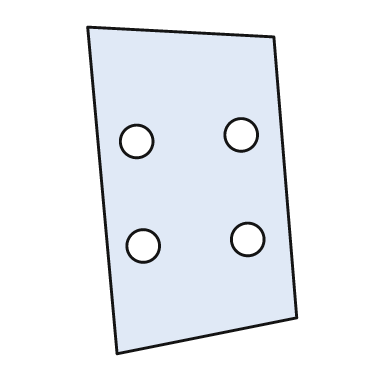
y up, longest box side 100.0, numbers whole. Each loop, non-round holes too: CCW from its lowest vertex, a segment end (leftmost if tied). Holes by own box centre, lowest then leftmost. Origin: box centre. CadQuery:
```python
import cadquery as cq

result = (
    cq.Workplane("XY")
    .moveTo(-23.0, -50.0)
    .lineTo(32.0, -39.0)
    .lineTo(25.0, 47.0)
    .lineTo(-32.0, 50.0)
    .close()
    .moveTo(-15.0, -17.0)
    .circle(5.0)
    .moveTo(17.0, -15.0)
    .circle(5.0)
    .moveTo(-17.0, 15.0)
    .circle(5.0)
    .moveTo(15.0, 17.0)
    .circle(5.0)
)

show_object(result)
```